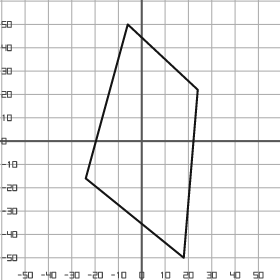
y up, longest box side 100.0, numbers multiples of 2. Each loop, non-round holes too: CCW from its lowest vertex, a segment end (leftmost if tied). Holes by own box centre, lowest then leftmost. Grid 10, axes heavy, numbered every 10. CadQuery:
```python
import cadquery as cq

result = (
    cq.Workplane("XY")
    .moveTo(18.0, -50.0)
    .lineTo(24.0, 22.0)
    .lineTo(-6.0, 50.0)
    .lineTo(-24.0, -16.0)
    .close()
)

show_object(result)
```